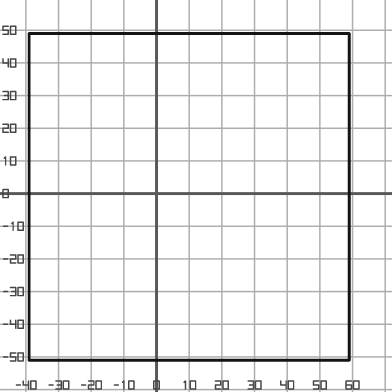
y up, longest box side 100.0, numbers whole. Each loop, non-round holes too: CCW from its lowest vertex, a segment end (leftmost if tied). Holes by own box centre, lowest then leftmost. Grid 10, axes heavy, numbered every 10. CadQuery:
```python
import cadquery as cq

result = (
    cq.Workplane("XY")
    .moveTo(-39.0, -51.0)
    .lineTo(59.0, -51.0)
    .lineTo(59.0, 49.0)
    .lineTo(-39.0, 49.0)
    .close()
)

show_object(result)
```